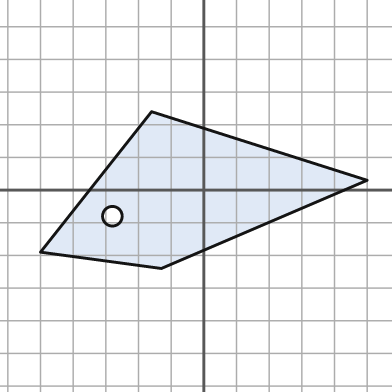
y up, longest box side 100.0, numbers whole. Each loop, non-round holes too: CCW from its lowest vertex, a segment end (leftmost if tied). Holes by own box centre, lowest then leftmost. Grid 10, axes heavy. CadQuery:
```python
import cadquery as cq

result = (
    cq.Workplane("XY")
    .moveTo(-13.0, -24.0)
    .lineTo(50.0, 3.0)
    .lineTo(-16.0, 24.0)
    .lineTo(-50.0, -19.0)
    .close()
    .moveTo(-28.0, -8.0)
    .circle(3.0)
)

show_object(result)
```